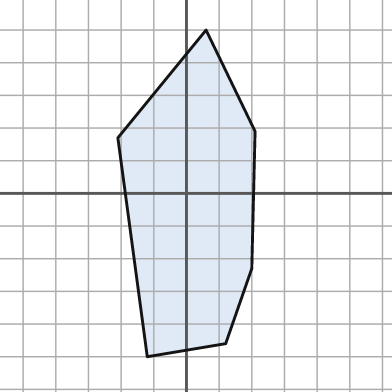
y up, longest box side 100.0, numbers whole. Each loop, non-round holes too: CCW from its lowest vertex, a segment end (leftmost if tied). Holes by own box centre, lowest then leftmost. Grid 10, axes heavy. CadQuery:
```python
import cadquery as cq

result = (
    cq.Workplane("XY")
    .moveTo(-12.0, -50.0)
    .lineTo(12.0, -46.0)
    .lineTo(20.0, -23.0)
    .lineTo(21.0, 19.0)
    .lineTo(6.0, 50.0)
    .lineTo(-21.0, 17.0)
    .close()
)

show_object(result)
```